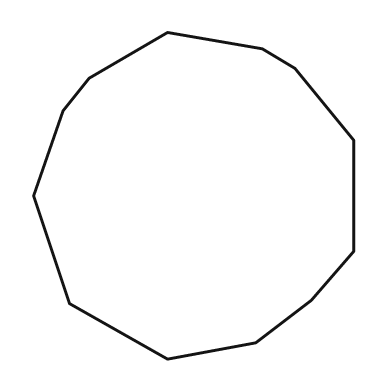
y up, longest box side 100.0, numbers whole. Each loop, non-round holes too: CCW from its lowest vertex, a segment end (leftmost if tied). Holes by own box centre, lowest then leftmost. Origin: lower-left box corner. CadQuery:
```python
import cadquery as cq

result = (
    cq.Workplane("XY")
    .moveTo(41.0, 0.0)
    .lineTo(68.0, 5.0)
    .lineTo(85.0, 18.0)
    .lineTo(98.0, 33.0)
    .lineTo(98.0, 67.0)
    .lineTo(80.0, 89.0)
    .lineTo(70.0, 95.0)
    .lineTo(41.0, 100.0)
    .lineTo(17.0, 86.0)
    .lineTo(9.0, 76.0)
    .lineTo(0.0, 50.0)
    .lineTo(11.0, 17.0)
    .close()
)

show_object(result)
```